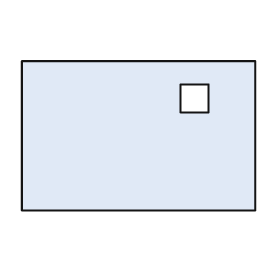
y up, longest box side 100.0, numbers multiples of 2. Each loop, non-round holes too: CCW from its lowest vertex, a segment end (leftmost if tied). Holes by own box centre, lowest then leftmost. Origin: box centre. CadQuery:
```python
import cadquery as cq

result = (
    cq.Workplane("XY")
    .moveTo(-50.0, -32.0)
    .lineTo(50.0, -32.0)
    .lineTo(50.0, 32.0)
    .lineTo(-50.0, 32.0)
    .close()
    .moveTo(18.0, 10.0)
    .lineTo(30.0, 10.0)
    .lineTo(30.0, 22.0)
    .lineTo(18.0, 22.0)
    .close()
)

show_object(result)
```